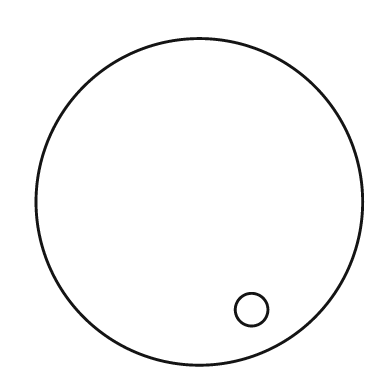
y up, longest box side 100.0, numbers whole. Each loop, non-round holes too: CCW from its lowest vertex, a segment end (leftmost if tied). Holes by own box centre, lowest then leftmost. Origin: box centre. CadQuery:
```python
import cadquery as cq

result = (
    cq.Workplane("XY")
    .moveTo(0.0, 0.0)
    .circle(50.0)
    .moveTo(16.0, -33.0)
    .circle(5.0)
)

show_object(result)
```